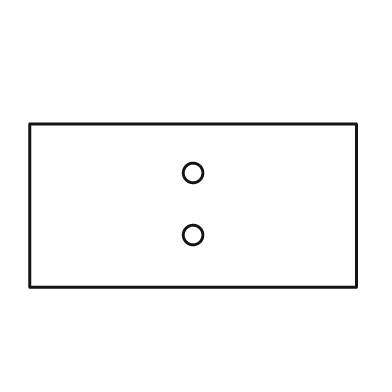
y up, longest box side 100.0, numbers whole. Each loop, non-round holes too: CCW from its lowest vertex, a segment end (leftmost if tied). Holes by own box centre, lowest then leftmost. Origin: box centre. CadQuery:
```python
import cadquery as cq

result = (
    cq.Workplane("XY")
    .moveTo(-50.0, -25.0)
    .lineTo(50.0, -25.0)
    .lineTo(50.0, 25.0)
    .lineTo(-50.0, 25.0)
    .close()
    .moveTo(0.0, -9.0)
    .circle(3.0)
    .moveTo(0.0, 10.0)
    .circle(3.0)
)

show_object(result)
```